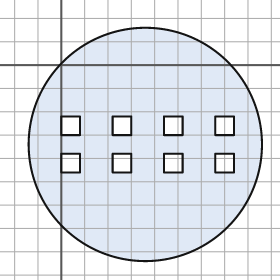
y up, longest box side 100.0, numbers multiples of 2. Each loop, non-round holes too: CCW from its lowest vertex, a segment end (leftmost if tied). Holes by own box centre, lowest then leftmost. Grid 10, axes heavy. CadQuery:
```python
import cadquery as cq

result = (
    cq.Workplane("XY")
    .moveTo(36.0, -34.0)
    .circle(50.0)
    .moveTo(0.0, -46.0)
    .lineTo(8.0, -46.0)
    .lineTo(8.0, -38.0)
    .lineTo(0.0, -38.0)
    .close()
    .moveTo(22.0, -46.0)
    .lineTo(30.0, -46.0)
    .lineTo(30.0, -38.0)
    .lineTo(22.0, -38.0)
    .close()
    .moveTo(44.0, -46.0)
    .lineTo(52.0, -46.0)
    .lineTo(52.0, -38.0)
    .lineTo(44.0, -38.0)
    .close()
    .moveTo(66.0, -46.0)
    .lineTo(74.0, -46.0)
    .lineTo(74.0, -38.0)
    .lineTo(66.0, -38.0)
    .close()
    .moveTo(0.0, -30.0)
    .lineTo(8.0, -30.0)
    .lineTo(8.0, -22.0)
    .lineTo(0.0, -22.0)
    .close()
    .moveTo(22.0, -30.0)
    .lineTo(30.0, -30.0)
    .lineTo(30.0, -22.0)
    .lineTo(22.0, -22.0)
    .close()
    .moveTo(44.0, -30.0)
    .lineTo(52.0, -30.0)
    .lineTo(52.0, -22.0)
    .lineTo(44.0, -22.0)
    .close()
    .moveTo(66.0, -30.0)
    .lineTo(74.0, -30.0)
    .lineTo(74.0, -22.0)
    .lineTo(66.0, -22.0)
    .close()
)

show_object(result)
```